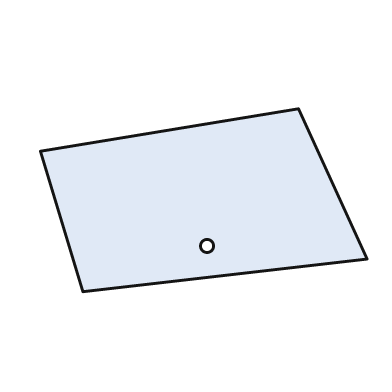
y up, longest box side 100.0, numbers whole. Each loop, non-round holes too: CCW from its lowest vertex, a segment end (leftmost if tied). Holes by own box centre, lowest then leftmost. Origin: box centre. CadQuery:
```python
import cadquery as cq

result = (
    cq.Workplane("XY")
    .moveTo(-37.0, -28.0)
    .lineTo(50.0, -18.0)
    .lineTo(29.0, 28.0)
    .lineTo(-50.0, 15.0)
    .close()
    .moveTo(1.0, -14.0)
    .circle(2.0)
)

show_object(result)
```